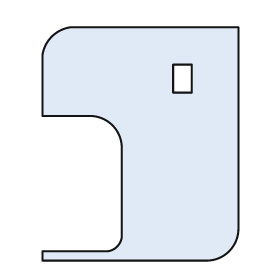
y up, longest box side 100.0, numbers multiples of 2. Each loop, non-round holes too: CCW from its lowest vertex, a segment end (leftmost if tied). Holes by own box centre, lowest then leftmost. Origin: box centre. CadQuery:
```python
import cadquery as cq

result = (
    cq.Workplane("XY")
    .moveTo(-42.0, -50.0)
    .lineTo(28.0, -50.0)
    .threePointArc((38.0, -46.0), (42.0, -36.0))
    .lineTo(42.0, 50.0)
    .lineTo(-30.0, 50.0)
    .threePointArc((-38.0, 46.0), (-42.0, 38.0))
    .lineTo(-42.0, 12.0)
    .lineTo(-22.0, 12.0)
    .threePointArc((-12.0, 8.0), (-8.0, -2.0))
    .lineTo(-8.0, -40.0)
    .threePointArc((-10.0, -44.0), (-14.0, -46.0))
    .lineTo(-42.0, -46.0)
    .close()
    .moveTo(14.0, 22.0)
    .lineTo(22.0, 22.0)
    .lineTo(22.0, 34.0)
    .lineTo(14.0, 34.0)
    .close()
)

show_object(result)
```